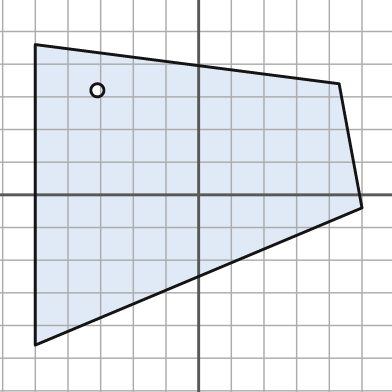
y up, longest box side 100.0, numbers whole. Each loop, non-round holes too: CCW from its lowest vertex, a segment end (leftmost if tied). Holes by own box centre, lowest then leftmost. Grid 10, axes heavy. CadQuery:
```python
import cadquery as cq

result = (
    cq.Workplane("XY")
    .moveTo(-50.0, -46.0)
    .lineTo(50.0, -4.0)
    .lineTo(43.0, 34.0)
    .lineTo(-50.0, 46.0)
    .close()
    .moveTo(-31.0, 32.0)
    .circle(2.0)
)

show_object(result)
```